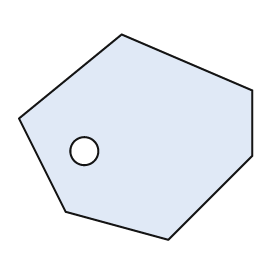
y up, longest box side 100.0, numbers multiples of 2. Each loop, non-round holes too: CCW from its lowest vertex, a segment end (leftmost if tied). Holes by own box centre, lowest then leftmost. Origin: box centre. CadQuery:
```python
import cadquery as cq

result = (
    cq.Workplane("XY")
    .moveTo(14.0, -44.0)
    .lineTo(50.0, -8.0)
    .lineTo(50.0, 20.0)
    .lineTo(-6.0, 44.0)
    .lineTo(-50.0, 8.0)
    .lineTo(-30.0, -32.0)
    .close()
    .moveTo(-22.0, -6.0)
    .circle(6.0)
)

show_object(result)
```